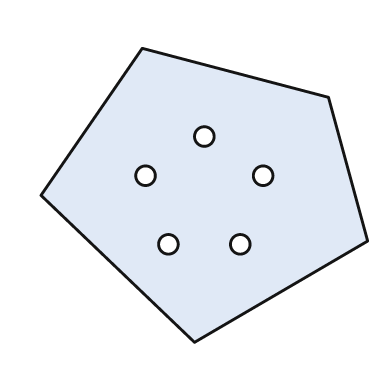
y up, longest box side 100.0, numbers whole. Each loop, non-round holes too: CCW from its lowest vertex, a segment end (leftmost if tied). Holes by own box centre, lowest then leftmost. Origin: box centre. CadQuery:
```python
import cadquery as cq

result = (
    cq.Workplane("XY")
    .moveTo(-3.0, -45.0)
    .lineTo(50.0, -14.0)
    .lineTo(38.0, 30.0)
    .lineTo(-19.0, 45.0)
    .lineTo(-50.0, 0.0)
    .close()
    .moveTo(-11.0, -15.0)
    .circle(3.0)
    .moveTo(11.0, -15.0)
    .circle(3.0)
    .moveTo(-18.0, 6.0)
    .circle(3.0)
    .moveTo(18.0, 6.0)
    .circle(3.0)
    .moveTo(0.0, 18.0)
    .circle(3.0)
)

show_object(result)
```